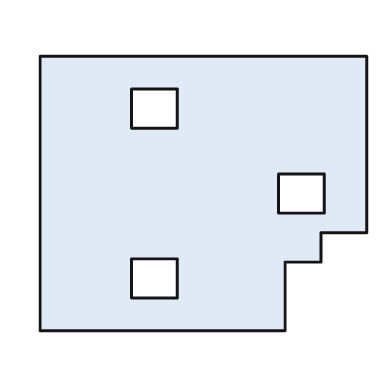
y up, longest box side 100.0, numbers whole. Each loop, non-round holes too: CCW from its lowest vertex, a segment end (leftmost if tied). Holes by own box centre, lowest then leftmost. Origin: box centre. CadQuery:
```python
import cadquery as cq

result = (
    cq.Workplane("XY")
    .moveTo(-50.0, -42.0)
    .lineTo(25.0, -42.0)
    .lineTo(25.0, -21.0)
    .lineTo(36.0, -21.0)
    .lineTo(36.0, -12.0)
    .lineTo(50.0, -12.0)
    .lineTo(50.0, 42.0)
    .lineTo(-50.0, 42.0)
    .close()
    .moveTo(-22.0, -32.0)
    .lineTo(-8.0, -32.0)
    .lineTo(-8.0, -20.0)
    .lineTo(-22.0, -20.0)
    .close()
    .moveTo(23.0, -6.0)
    .lineTo(37.0, -6.0)
    .lineTo(37.0, 6.0)
    .lineTo(23.0, 6.0)
    .close()
    .moveTo(-22.0, 20.0)
    .lineTo(-8.0, 20.0)
    .lineTo(-8.0, 32.0)
    .lineTo(-22.0, 32.0)
    .close()
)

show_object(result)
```